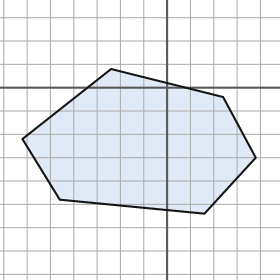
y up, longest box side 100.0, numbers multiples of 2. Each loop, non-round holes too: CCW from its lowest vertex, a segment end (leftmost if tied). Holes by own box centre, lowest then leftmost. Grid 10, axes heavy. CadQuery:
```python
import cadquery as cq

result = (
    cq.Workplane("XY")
    .moveTo(16.0, -54.0)
    .lineTo(38.0, -30.0)
    .lineTo(24.0, -4.0)
    .lineTo(-24.0, 8.0)
    .lineTo(-62.0, -22.0)
    .lineTo(-46.0, -48.0)
    .close()
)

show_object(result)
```